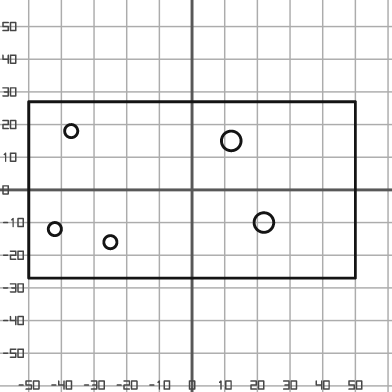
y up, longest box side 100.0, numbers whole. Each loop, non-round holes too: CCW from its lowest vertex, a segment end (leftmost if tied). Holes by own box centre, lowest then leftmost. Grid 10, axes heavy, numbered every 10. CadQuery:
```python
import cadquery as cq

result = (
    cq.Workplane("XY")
    .moveTo(-50.0, -27.0)
    .lineTo(50.0, -27.0)
    .lineTo(50.0, 27.0)
    .lineTo(-50.0, 27.0)
    .close()
    .moveTo(-25.0, -16.0)
    .circle(2.0)
    .moveTo(-42.0, -12.0)
    .circle(2.0)
    .moveTo(22.0, -10.0)
    .circle(3.0)
    .moveTo(12.0, 15.0)
    .circle(3.0)
    .moveTo(-37.0, 18.0)
    .circle(2.0)
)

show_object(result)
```